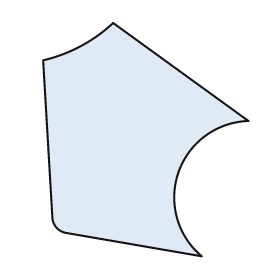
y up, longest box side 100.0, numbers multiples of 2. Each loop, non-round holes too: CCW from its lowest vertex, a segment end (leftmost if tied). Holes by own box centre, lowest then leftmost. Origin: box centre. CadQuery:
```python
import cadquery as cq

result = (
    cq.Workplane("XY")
    .moveTo(24.0, -50.0)
    .threePointArc((14.0, -14.0), (44.0, 8.0))
    .lineTo(-14.0, 50.0)
    .threePointArc((-28.0, 40.0), (-44.0, 34.0))
    .lineTo(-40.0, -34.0)
    .threePointArc((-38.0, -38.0), (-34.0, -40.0))
    .close()
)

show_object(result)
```